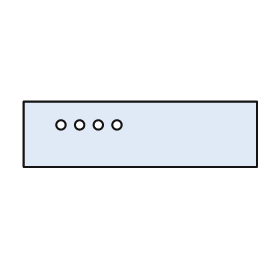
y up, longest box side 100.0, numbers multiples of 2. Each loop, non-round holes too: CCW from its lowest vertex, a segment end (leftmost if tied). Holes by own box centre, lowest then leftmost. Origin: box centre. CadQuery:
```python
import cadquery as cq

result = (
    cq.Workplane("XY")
    .moveTo(-50.0, -14.0)
    .lineTo(50.0, -14.0)
    .lineTo(50.0, 14.0)
    .lineTo(-50.0, 14.0)
    .close()
    .moveTo(-34.0, 4.0)
    .circle(2.0)
    .moveTo(-26.0, 4.0)
    .circle(2.0)
    .moveTo(-18.0, 4.0)
    .circle(2.0)
    .moveTo(-10.0, 4.0)
    .circle(2.0)
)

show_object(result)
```